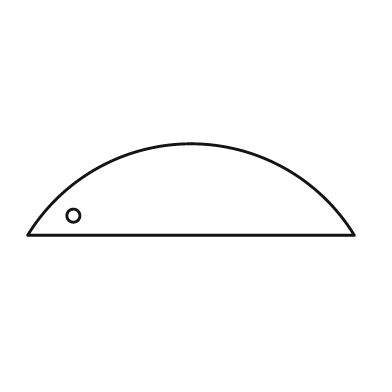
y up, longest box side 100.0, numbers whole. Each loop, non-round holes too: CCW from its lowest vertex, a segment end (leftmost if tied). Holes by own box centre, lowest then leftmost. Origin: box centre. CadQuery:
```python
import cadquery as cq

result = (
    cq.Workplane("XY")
    .moveTo(-50.0, -14.0)
    .lineTo(50.0, -14.0)
    .threePointArc((0.0, 14.0), (-50.0, -14.0))
    .close()
    .moveTo(-36.0, -8.0)
    .circle(2.0)
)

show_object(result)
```